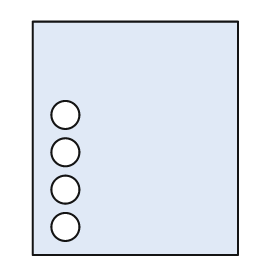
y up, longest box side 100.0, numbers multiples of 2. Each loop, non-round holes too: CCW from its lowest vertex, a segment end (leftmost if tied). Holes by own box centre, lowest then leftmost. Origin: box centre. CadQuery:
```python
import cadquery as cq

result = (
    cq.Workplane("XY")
    .moveTo(-44.0, -50.0)
    .lineTo(44.0, -50.0)
    .lineTo(44.0, 50.0)
    .lineTo(-44.0, 50.0)
    .close()
    .moveTo(-30.0, -38.0)
    .circle(6.0)
    .moveTo(-30.0, -22.0)
    .circle(6.0)
    .moveTo(-30.0, -6.0)
    .circle(6.0)
    .moveTo(-30.0, 10.0)
    .circle(6.0)
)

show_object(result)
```